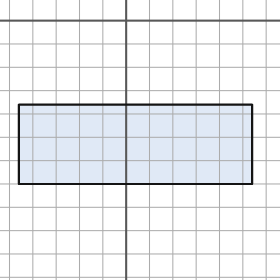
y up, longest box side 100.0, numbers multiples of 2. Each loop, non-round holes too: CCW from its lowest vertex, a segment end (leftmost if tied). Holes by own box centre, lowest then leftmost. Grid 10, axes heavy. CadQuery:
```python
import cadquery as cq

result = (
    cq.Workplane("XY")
    .moveTo(-46.0, -70.0)
    .lineTo(54.0, -70.0)
    .lineTo(54.0, -36.0)
    .lineTo(-46.0, -36.0)
    .close()
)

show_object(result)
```